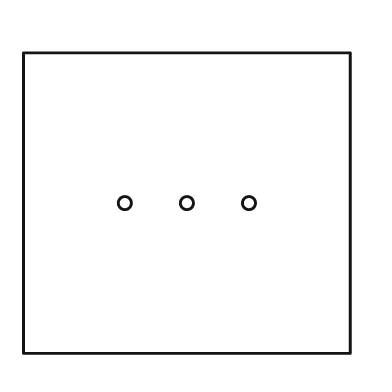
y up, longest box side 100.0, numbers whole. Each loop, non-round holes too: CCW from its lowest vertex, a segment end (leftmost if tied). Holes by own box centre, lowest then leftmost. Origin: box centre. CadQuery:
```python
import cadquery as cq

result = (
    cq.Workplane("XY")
    .moveTo(-50.0, -46.0)
    .lineTo(50.0, -46.0)
    .lineTo(50.0, 46.0)
    .lineTo(-50.0, 46.0)
    .close()
    .moveTo(-19.0, 0.0)
    .circle(2.0)
    .moveTo(0.0, 0.0)
    .circle(2.0)
    .moveTo(19.0, 0.0)
    .circle(2.0)
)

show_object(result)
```